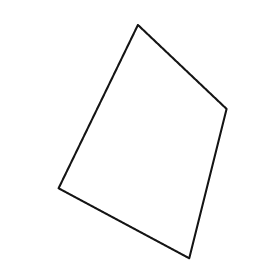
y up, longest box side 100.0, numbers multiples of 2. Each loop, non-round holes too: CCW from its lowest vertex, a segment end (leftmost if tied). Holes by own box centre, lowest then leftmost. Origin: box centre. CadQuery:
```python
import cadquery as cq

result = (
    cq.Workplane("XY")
    .moveTo(20.0, -50.0)
    .lineTo(36.0, 14.0)
    .lineTo(-2.0, 50.0)
    .lineTo(-36.0, -20.0)
    .close()
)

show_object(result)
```